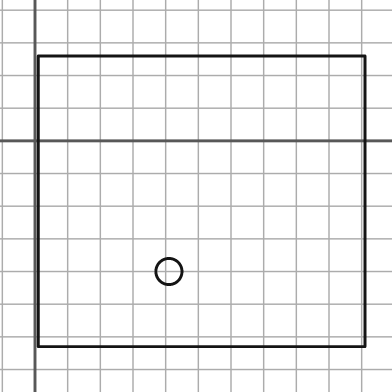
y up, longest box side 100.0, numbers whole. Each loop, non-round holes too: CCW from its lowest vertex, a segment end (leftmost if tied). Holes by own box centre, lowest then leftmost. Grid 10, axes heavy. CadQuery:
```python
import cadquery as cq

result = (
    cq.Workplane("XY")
    .moveTo(1.0, -63.0)
    .lineTo(101.0, -63.0)
    .lineTo(101.0, 26.0)
    .lineTo(1.0, 26.0)
    .close()
    .moveTo(41.0, -40.0)
    .circle(4.0)
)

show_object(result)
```